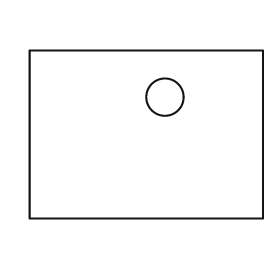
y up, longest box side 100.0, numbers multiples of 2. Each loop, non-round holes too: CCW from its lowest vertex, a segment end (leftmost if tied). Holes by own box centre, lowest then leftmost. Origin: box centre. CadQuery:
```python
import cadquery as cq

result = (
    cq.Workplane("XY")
    .moveTo(-50.0, -36.0)
    .lineTo(50.0, -36.0)
    .lineTo(50.0, 36.0)
    .lineTo(-50.0, 36.0)
    .close()
    .moveTo(8.0, 16.0)
    .circle(8.0)
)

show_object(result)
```